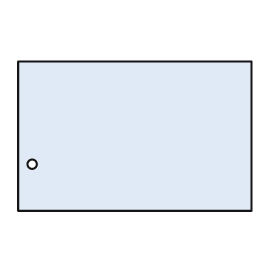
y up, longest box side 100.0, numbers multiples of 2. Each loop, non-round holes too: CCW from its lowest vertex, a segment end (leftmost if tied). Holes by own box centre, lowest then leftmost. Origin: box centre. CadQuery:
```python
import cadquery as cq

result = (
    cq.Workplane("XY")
    .moveTo(-50.0, -32.0)
    .lineTo(50.0, -32.0)
    .lineTo(50.0, 32.0)
    .lineTo(-50.0, 32.0)
    .close()
    .moveTo(-44.0, -12.0)
    .circle(2.0)
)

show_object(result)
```